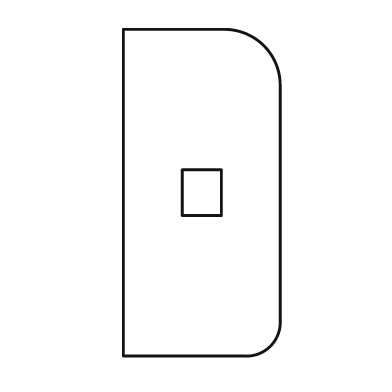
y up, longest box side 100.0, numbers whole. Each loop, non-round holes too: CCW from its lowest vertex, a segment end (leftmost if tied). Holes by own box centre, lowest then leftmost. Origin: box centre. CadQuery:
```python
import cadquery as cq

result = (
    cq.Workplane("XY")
    .moveTo(-24.0, -50.0)
    .lineTo(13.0, -50.0)
    .threePointArc((21.0, -47.0), (24.0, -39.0))
    .lineTo(24.0, 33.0)
    .threePointArc((19.0, 45.0), (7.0, 50.0))
    .lineTo(-24.0, 50.0)
    .close()
    .moveTo(-6.0, -7.0)
    .lineTo(6.0, -7.0)
    .lineTo(6.0, 7.0)
    .lineTo(-6.0, 7.0)
    .close()
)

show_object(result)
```